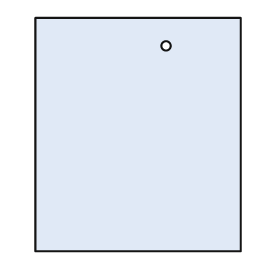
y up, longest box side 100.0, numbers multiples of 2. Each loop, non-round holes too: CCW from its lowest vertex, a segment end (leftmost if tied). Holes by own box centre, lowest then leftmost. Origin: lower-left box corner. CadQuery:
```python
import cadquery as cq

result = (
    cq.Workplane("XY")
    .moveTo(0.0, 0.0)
    .lineTo(88.0, 0.0)
    .lineTo(88.0, 100.0)
    .lineTo(0.0, 100.0)
    .close()
    .moveTo(56.0, 88.0)
    .circle(2.0)
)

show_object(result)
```